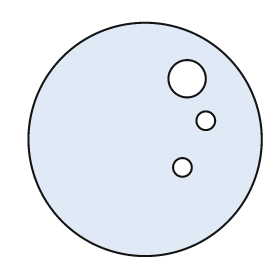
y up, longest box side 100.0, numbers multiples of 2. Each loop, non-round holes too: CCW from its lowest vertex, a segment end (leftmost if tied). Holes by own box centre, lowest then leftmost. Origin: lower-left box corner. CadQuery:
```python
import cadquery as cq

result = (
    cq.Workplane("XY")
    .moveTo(50.0, 50.0)
    .circle(50.0)
    .moveTo(66.0, 38.0)
    .circle(4.0)
    .moveTo(76.0, 58.0)
    .circle(4.0)
    .moveTo(68.0, 76.0)
    .circle(8.0)
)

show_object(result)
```